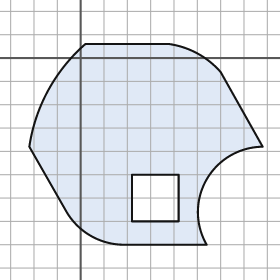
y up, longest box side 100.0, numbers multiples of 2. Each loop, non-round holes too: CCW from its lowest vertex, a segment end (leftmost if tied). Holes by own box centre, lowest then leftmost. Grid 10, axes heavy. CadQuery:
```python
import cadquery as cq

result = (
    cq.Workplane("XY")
    .moveTo(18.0, -80.0)
    .lineTo(54.0, -80.0)
    .threePointArc((54.0, -52.0), (78.0, -38.0))
    .lineTo(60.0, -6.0)
    .threePointArc((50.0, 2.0), (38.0, 6.0))
    .lineTo(2.0, 6.0)
    .threePointArc((-14.0, -14.0), (-22.0, -38.0))
    .lineTo(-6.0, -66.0)
    .threePointArc((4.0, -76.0), (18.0, -80.0))
    .close()
    .moveTo(22.0, -70.0)
    .lineTo(42.0, -70.0)
    .lineTo(42.0, -50.0)
    .lineTo(22.0, -50.0)
    .close()
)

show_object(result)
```